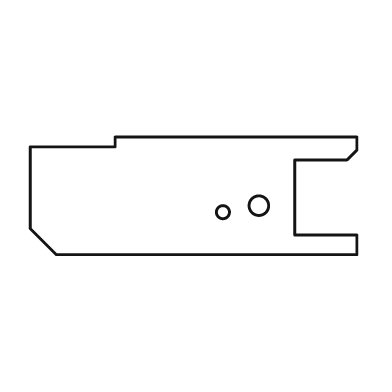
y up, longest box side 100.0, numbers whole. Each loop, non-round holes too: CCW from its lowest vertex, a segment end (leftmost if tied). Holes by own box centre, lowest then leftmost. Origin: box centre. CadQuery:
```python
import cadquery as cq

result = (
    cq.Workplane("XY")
    .moveTo(-42.0, -18.0)
    .lineTo(50.0, -18.0)
    .lineTo(50.0, -12.0)
    .lineTo(31.0, -12.0)
    .lineTo(31.0, 11.0)
    .lineTo(47.0, 11.0)
    .lineTo(50.0, 14.0)
    .lineTo(50.0, 18.0)
    .lineTo(-24.0, 18.0)
    .lineTo(-24.0, 15.0)
    .lineTo(-50.0, 15.0)
    .lineTo(-50.0, -10.0)
    .close()
    .moveTo(9.0, -5.0)
    .circle(2.0)
    .moveTo(20.0, -3.0)
    .circle(3.0)
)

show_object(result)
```